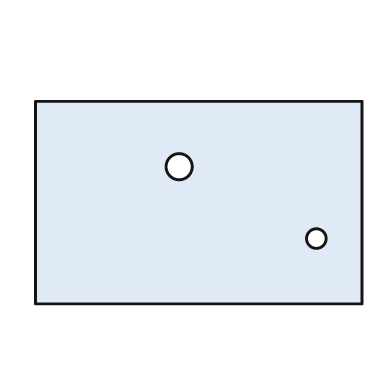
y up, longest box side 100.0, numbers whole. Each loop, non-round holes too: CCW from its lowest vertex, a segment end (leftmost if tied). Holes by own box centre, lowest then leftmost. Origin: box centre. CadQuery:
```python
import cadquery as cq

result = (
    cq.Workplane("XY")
    .moveTo(-50.0, -31.0)
    .lineTo(50.0, -31.0)
    .lineTo(50.0, 31.0)
    .lineTo(-50.0, 31.0)
    .close()
    .moveTo(36.0, -11.0)
    .circle(3.0)
    .moveTo(-6.0, 11.0)
    .circle(4.0)
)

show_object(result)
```